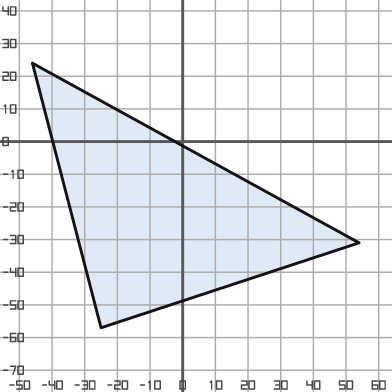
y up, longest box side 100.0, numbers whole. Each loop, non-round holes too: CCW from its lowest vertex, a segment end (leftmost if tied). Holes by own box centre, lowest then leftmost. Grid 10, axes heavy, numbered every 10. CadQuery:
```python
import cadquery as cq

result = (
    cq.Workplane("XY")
    .moveTo(-25.0, -57.0)
    .lineTo(54.0, -31.0)
    .lineTo(-46.0, 24.0)
    .close()
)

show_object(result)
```